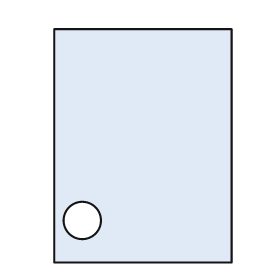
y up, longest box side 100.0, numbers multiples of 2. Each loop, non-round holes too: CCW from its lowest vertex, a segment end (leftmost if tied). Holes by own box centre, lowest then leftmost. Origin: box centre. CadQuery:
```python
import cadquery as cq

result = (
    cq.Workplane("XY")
    .moveTo(-38.0, -50.0)
    .lineTo(38.0, -50.0)
    .lineTo(38.0, 50.0)
    .lineTo(-38.0, 50.0)
    .close()
    .moveTo(-26.0, -32.0)
    .circle(8.0)
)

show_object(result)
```